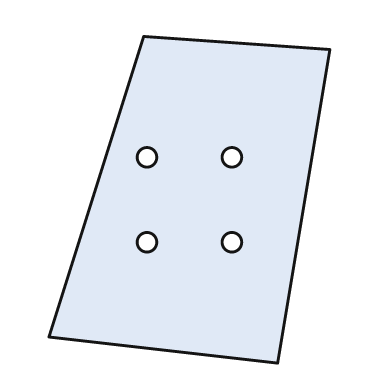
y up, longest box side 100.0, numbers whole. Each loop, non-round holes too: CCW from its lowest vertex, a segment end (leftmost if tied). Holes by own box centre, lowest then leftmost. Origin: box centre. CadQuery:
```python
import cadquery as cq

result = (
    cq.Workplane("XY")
    .moveTo(27.0, -50.0)
    .lineTo(43.0, 46.0)
    .lineTo(-14.0, 50.0)
    .lineTo(-43.0, -42.0)
    .close()
    .moveTo(-13.0, -13.0)
    .circle(3.0)
    .moveTo(13.0, -13.0)
    .circle(3.0)
    .moveTo(-13.0, 13.0)
    .circle(3.0)
    .moveTo(13.0, 13.0)
    .circle(3.0)
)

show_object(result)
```